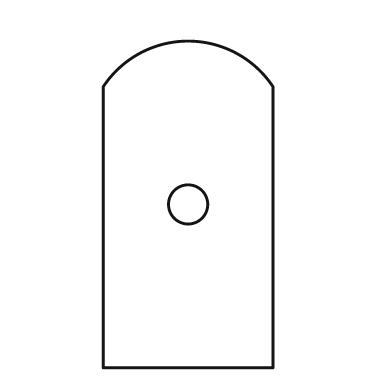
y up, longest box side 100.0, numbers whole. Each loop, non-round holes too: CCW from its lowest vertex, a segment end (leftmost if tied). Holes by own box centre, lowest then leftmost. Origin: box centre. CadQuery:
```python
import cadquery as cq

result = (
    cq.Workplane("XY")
    .moveTo(-26.0, -50.0)
    .lineTo(26.0, -50.0)
    .lineTo(26.0, 36.0)
    .threePointArc((0.0, 50.0), (-26.0, 36.0))
    .close()
    .moveTo(0.0, 0.0)
    .circle(6.0)
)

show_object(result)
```